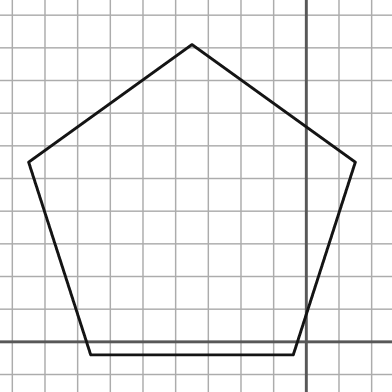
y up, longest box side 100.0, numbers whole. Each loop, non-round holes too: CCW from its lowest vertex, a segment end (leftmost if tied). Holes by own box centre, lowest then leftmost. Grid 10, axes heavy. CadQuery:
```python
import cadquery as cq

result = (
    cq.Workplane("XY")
    .moveTo(-66.0, -4.0)
    .lineTo(-4.0, -4.0)
    .lineTo(15.0, 55.0)
    .lineTo(-35.0, 91.0)
    .lineTo(-85.0, 55.0)
    .close()
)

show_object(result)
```